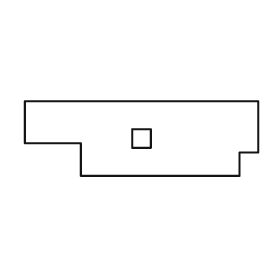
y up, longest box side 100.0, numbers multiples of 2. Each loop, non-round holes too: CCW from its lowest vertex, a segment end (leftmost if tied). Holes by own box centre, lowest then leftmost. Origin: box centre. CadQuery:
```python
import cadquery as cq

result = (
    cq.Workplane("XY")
    .moveTo(-26.0, -16.0)
    .lineTo(42.0, -16.0)
    .lineTo(42.0, -6.0)
    .lineTo(50.0, -6.0)
    .lineTo(50.0, 16.0)
    .lineTo(-50.0, 16.0)
    .lineTo(-50.0, -2.0)
    .lineTo(-26.0, -2.0)
    .close()
    .moveTo(-4.0, -4.0)
    .lineTo(4.0, -4.0)
    .lineTo(4.0, 4.0)
    .lineTo(-4.0, 4.0)
    .close()
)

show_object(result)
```